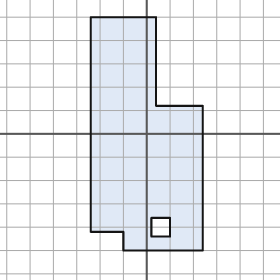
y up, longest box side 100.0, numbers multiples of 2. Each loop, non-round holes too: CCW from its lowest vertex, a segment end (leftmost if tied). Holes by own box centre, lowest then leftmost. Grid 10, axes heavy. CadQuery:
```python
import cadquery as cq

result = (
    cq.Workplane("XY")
    .moveTo(-10.0, -50.0)
    .lineTo(24.0, -50.0)
    .lineTo(24.0, 12.0)
    .lineTo(4.0, 12.0)
    .lineTo(4.0, 50.0)
    .lineTo(-24.0, 50.0)
    .lineTo(-24.0, -42.0)
    .lineTo(-10.0, -42.0)
    .close()
    .moveTo(2.0, -44.0)
    .lineTo(10.0, -44.0)
    .lineTo(10.0, -36.0)
    .lineTo(2.0, -36.0)
    .close()
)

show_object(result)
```